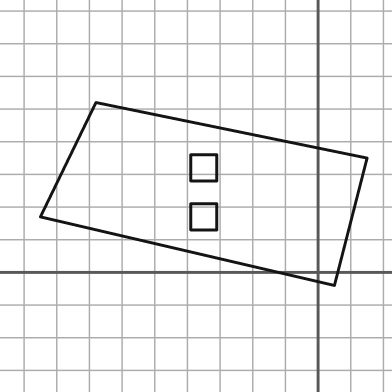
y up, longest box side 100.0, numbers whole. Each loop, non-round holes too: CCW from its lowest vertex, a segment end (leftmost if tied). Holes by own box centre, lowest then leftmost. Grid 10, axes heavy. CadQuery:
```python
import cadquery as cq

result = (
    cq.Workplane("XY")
    .moveTo(5.0, -4.0)
    .lineTo(15.0, 35.0)
    .lineTo(-68.0, 52.0)
    .lineTo(-85.0, 17.0)
    .close()
    .moveTo(-39.0, 13.0)
    .lineTo(-31.0, 13.0)
    .lineTo(-31.0, 21.0)
    .lineTo(-39.0, 21.0)
    .close()
    .moveTo(-39.0, 28.0)
    .lineTo(-31.0, 28.0)
    .lineTo(-31.0, 36.0)
    .lineTo(-39.0, 36.0)
    .close()
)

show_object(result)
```